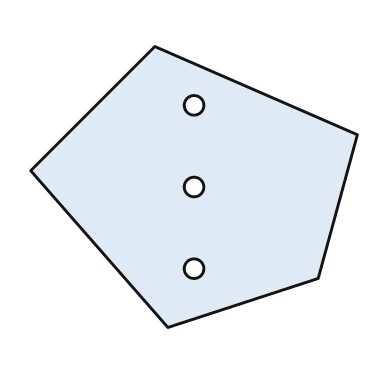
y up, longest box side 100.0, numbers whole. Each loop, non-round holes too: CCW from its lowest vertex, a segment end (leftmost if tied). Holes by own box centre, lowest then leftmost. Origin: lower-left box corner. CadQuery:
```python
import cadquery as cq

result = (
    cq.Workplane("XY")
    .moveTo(42.0, 0.0)
    .lineTo(88.0, 15.0)
    .lineTo(100.0, 59.0)
    .lineTo(38.0, 86.0)
    .lineTo(0.0, 48.0)
    .close()
    .moveTo(50.0, 18.0)
    .circle(3.0)
    .moveTo(50.0, 43.0)
    .circle(3.0)
    .moveTo(50.0, 68.0)
    .circle(3.0)
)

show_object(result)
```